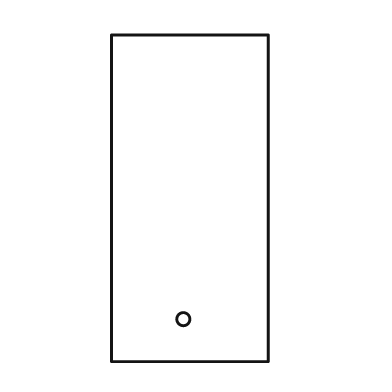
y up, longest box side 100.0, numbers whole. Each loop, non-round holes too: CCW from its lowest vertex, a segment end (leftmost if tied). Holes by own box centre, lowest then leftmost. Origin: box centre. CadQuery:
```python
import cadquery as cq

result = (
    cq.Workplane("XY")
    .moveTo(-24.0, -50.0)
    .lineTo(24.0, -50.0)
    .lineTo(24.0, 50.0)
    .lineTo(-24.0, 50.0)
    .close()
    .moveTo(-2.0, -37.0)
    .circle(2.0)
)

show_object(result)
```